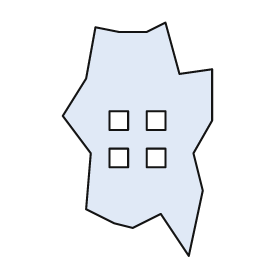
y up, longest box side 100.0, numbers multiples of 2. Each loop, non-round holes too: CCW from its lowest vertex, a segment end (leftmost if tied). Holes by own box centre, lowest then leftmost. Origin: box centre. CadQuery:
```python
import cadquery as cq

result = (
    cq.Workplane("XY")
    .moveTo(22.0, -50.0)
    .lineTo(28.0, -22.0)
    .lineTo(24.0, -6.0)
    .lineTo(32.0, 8.0)
    .lineTo(32.0, 30.0)
    .lineTo(18.0, 28.0)
    .lineTo(12.0, 50.0)
    .lineTo(4.0, 46.0)
    .lineTo(-8.0, 46.0)
    .lineTo(-18.0, 48.0)
    .lineTo(-22.0, 26.0)
    .lineTo(-32.0, 10.0)
    .lineTo(-20.0, -6.0)
    .lineTo(-22.0, -30.0)
    .lineTo(-10.0, -36.0)
    .lineTo(-2.0, -38.0)
    .lineTo(10.0, -32.0)
    .close()
    .moveTo(-12.0, -12.0)
    .lineTo(-4.0, -12.0)
    .lineTo(-4.0, -4.0)
    .lineTo(-12.0, -4.0)
    .close()
    .moveTo(4.0, -12.0)
    .lineTo(12.0, -12.0)
    .lineTo(12.0, -4.0)
    .lineTo(4.0, -4.0)
    .close()
    .moveTo(-12.0, 4.0)
    .lineTo(-4.0, 4.0)
    .lineTo(-4.0, 12.0)
    .lineTo(-12.0, 12.0)
    .close()
    .moveTo(4.0, 4.0)
    .lineTo(12.0, 4.0)
    .lineTo(12.0, 12.0)
    .lineTo(4.0, 12.0)
    .close()
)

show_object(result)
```